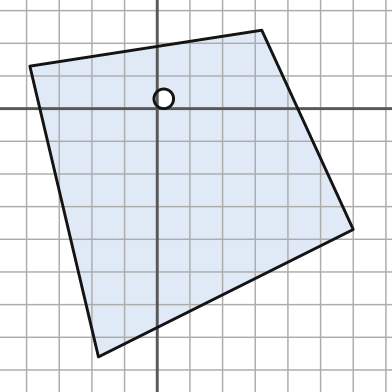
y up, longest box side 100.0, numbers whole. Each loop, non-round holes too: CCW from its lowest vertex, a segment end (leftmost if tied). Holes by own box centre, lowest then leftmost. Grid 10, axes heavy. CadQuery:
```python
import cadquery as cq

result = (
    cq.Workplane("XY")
    .moveTo(-18.0, -76.0)
    .lineTo(60.0, -37.0)
    .lineTo(32.0, 24.0)
    .lineTo(-39.0, 13.0)
    .close()
    .moveTo(2.0, 3.0)
    .circle(3.0)
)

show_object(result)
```